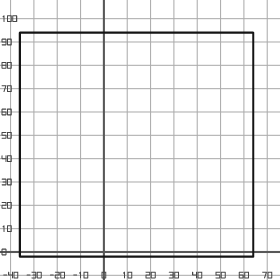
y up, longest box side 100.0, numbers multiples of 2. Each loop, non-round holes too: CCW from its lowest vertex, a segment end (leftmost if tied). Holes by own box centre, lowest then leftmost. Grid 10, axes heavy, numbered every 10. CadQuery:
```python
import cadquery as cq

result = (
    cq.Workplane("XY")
    .moveTo(-36.0, -2.0)
    .lineTo(64.0, -2.0)
    .lineTo(64.0, 94.0)
    .lineTo(-36.0, 94.0)
    .close()
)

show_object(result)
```